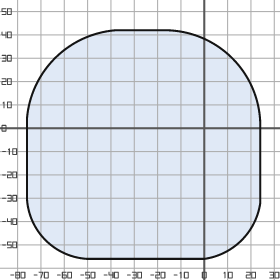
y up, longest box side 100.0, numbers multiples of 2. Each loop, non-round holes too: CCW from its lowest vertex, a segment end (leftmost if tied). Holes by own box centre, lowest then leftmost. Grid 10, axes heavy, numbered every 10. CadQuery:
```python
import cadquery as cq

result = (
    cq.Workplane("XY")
    .moveTo(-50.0, -56.0)
    .lineTo(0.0, -56.0)
    .threePointArc((16.0, -48.0), (24.0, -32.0))
    .lineTo(24.0, 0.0)
    .threePointArc((12.0, 30.0), (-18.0, 42.0))
    .lineTo(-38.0, 42.0)
    .threePointArc((-64.0, 30.0), (-76.0, 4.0))
    .lineTo(-76.0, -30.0)
    .threePointArc((-68.0, -48.0), (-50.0, -56.0))
    .close()
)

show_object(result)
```